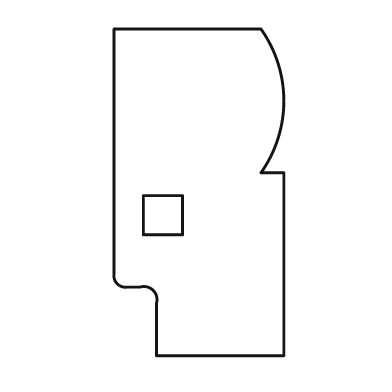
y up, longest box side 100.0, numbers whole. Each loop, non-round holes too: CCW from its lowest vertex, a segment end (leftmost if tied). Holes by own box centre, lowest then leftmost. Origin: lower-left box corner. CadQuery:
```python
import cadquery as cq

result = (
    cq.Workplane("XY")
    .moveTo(13.0, 0.0)
    .lineTo(52.0, 0.0)
    .lineTo(52.0, 56.0)
    .lineTo(45.0, 56.0)
    .threePointArc((52.0, 78.0), (45.0, 100.0))
    .lineTo(0.0, 100.0)
    .lineTo(0.0, 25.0)
    .threePointArc((1.0, 22.0), (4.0, 21.0))
    .lineTo(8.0, 21.0)
    .threePointArc((12.0, 20.0), (13.0, 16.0))
    .close()
    .moveTo(9.0, 37.0)
    .lineTo(21.0, 37.0)
    .lineTo(21.0, 49.0)
    .lineTo(9.0, 49.0)
    .close()
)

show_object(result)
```